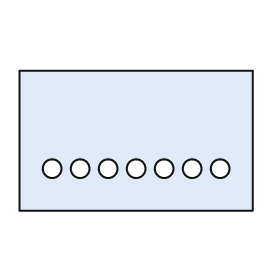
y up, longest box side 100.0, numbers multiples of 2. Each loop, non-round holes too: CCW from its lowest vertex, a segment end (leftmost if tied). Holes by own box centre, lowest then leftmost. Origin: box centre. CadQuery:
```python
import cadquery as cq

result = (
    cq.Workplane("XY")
    .moveTo(-50.0, -30.0)
    .lineTo(50.0, -30.0)
    .lineTo(50.0, 30.0)
    .lineTo(-50.0, 30.0)
    .close()
    .moveTo(-36.0, -12.0)
    .circle(4.0)
    .moveTo(-24.0, -12.0)
    .circle(4.0)
    .moveTo(-12.0, -12.0)
    .circle(4.0)
    .moveTo(0.0, -12.0)
    .circle(4.0)
    .moveTo(12.0, -12.0)
    .circle(4.0)
    .moveTo(24.0, -12.0)
    .circle(4.0)
    .moveTo(36.0, -12.0)
    .circle(4.0)
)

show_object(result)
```